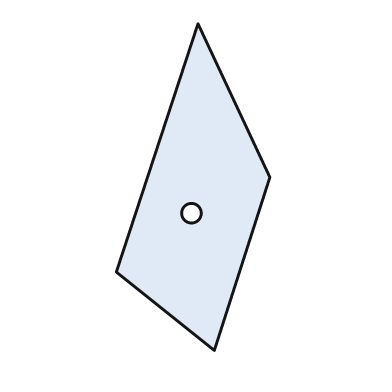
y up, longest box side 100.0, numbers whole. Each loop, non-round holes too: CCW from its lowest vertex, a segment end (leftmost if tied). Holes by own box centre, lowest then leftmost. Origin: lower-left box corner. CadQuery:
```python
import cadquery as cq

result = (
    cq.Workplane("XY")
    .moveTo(30.0, 0.0)
    .lineTo(47.0, 53.0)
    .lineTo(25.0, 100.0)
    .lineTo(0.0, 24.0)
    .close()
    .moveTo(23.0, 42.0)
    .circle(3.0)
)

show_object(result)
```